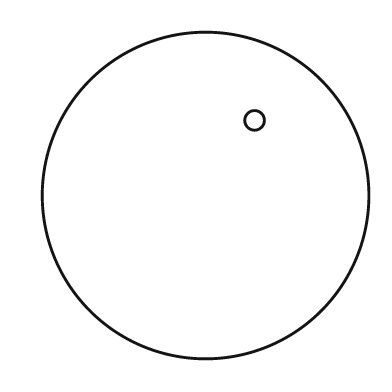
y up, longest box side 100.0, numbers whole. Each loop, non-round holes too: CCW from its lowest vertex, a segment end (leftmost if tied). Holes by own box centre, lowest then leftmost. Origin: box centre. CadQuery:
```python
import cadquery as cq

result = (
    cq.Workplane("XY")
    .moveTo(0.0, 0.0)
    .circle(50.0)
    .moveTo(15.0, 23.0)
    .circle(3.0)
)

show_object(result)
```